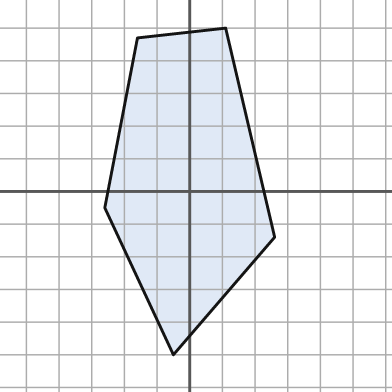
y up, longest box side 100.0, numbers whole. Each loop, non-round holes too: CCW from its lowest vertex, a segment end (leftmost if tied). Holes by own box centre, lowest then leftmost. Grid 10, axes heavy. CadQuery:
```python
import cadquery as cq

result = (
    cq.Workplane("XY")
    .moveTo(-5.0, -50.0)
    .lineTo(26.0, -14.0)
    .lineTo(11.0, 50.0)
    .lineTo(-16.0, 47.0)
    .lineTo(-26.0, -5.0)
    .close()
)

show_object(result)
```